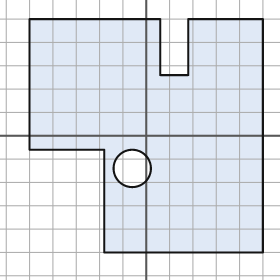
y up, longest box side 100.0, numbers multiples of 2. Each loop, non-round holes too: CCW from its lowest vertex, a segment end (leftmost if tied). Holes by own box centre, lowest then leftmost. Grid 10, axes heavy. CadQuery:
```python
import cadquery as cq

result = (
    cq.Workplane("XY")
    .moveTo(-18.0, -50.0)
    .lineTo(50.0, -50.0)
    .lineTo(50.0, 50.0)
    .lineTo(18.0, 50.0)
    .lineTo(18.0, 26.0)
    .lineTo(6.0, 26.0)
    .lineTo(6.0, 50.0)
    .lineTo(-50.0, 50.0)
    .lineTo(-50.0, -6.0)
    .lineTo(-18.0, -6.0)
    .close()
    .moveTo(-6.0, -14.0)
    .circle(8.0)
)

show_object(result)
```